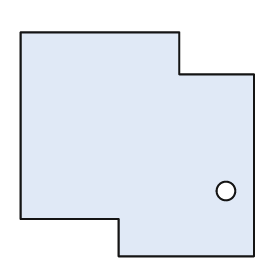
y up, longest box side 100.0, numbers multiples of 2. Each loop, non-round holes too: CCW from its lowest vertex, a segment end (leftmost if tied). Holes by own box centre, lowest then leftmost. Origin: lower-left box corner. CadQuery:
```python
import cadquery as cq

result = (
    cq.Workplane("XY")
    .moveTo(42.0, 0.0)
    .lineTo(100.0, 0.0)
    .lineTo(100.0, 78.0)
    .lineTo(68.0, 78.0)
    .lineTo(68.0, 96.0)
    .lineTo(0.0, 96.0)
    .lineTo(0.0, 16.0)
    .lineTo(42.0, 16.0)
    .close()
    .moveTo(88.0, 28.0)
    .circle(4.0)
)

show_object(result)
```